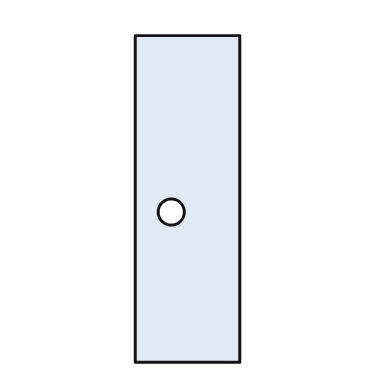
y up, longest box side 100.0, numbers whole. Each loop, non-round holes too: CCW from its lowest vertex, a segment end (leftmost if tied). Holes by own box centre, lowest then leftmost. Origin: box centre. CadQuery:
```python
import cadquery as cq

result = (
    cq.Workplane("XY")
    .moveTo(-16.0, -50.0)
    .lineTo(16.0, -50.0)
    .lineTo(16.0, 50.0)
    .lineTo(-16.0, 50.0)
    .close()
    .moveTo(-5.0, -4.0)
    .circle(4.0)
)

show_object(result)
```